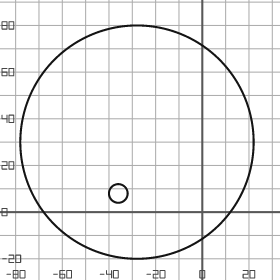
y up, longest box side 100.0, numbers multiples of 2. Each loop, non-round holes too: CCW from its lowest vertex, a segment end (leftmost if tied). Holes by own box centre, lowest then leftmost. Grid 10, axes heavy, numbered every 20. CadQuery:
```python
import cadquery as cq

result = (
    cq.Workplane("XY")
    .moveTo(-28.0, 30.0)
    .circle(50.0)
    .moveTo(-36.0, 8.0)
    .circle(4.0)
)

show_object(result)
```